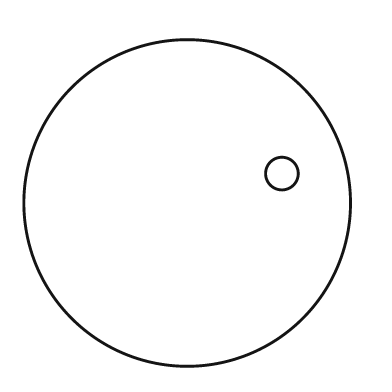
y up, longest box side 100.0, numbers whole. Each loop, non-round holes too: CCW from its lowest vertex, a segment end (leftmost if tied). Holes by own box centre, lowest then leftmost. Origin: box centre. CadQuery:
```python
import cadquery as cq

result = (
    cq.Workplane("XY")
    .moveTo(0.0, 0.0)
    .circle(50.0)
    .moveTo(29.0, 9.0)
    .circle(5.0)
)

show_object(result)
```